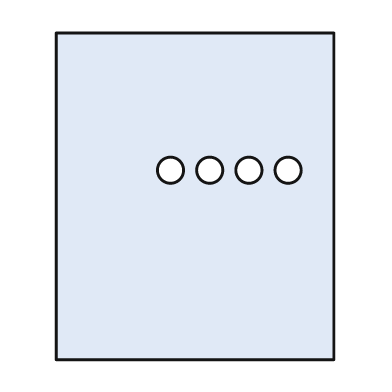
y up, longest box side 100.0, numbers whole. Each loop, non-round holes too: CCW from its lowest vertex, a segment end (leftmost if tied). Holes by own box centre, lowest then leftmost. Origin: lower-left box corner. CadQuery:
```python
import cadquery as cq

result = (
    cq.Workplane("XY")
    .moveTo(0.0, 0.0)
    .lineTo(85.0, 0.0)
    .lineTo(85.0, 100.0)
    .lineTo(0.0, 100.0)
    .close()
    .moveTo(35.0, 58.0)
    .circle(4.0)
    .moveTo(47.0, 58.0)
    .circle(4.0)
    .moveTo(59.0, 58.0)
    .circle(4.0)
    .moveTo(71.0, 58.0)
    .circle(4.0)
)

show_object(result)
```